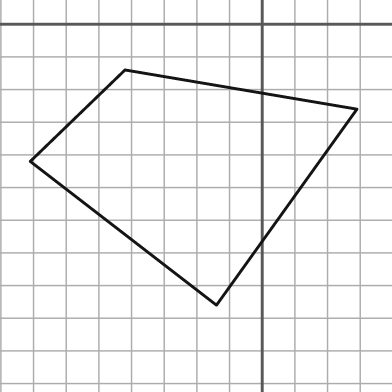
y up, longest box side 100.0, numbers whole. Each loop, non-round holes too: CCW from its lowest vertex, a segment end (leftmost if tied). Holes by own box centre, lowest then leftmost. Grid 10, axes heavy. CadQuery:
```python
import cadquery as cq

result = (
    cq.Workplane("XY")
    .moveTo(-14.0, -86.0)
    .lineTo(29.0, -26.0)
    .lineTo(-42.0, -14.0)
    .lineTo(-71.0, -42.0)
    .close()
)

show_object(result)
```